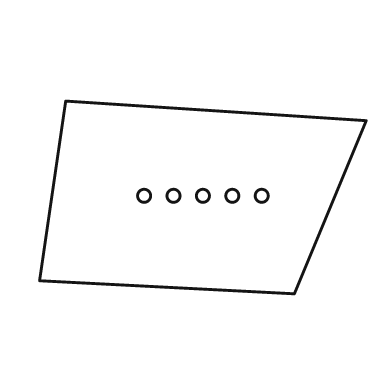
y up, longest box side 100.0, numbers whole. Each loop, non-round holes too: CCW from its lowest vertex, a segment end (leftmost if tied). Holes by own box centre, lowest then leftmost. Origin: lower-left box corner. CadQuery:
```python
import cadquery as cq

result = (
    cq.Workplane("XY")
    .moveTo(78.0, 0.0)
    .lineTo(100.0, 53.0)
    .lineTo(8.0, 59.0)
    .lineTo(0.0, 4.0)
    .close()
    .moveTo(32.0, 30.0)
    .circle(2.0)
    .moveTo(41.0, 30.0)
    .circle(2.0)
    .moveTo(50.0, 30.0)
    .circle(2.0)
    .moveTo(59.0, 30.0)
    .circle(2.0)
    .moveTo(68.0, 30.0)
    .circle(2.0)
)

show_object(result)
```